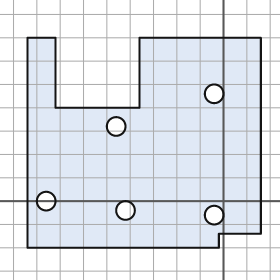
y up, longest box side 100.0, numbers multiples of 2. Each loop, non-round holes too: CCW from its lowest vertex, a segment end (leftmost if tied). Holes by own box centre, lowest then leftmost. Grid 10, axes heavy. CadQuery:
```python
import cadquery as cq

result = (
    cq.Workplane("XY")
    .moveTo(-84.0, -20.0)
    .lineTo(-2.0, -20.0)
    .lineTo(-2.0, -14.0)
    .lineTo(16.0, -14.0)
    .lineTo(16.0, 70.0)
    .lineTo(-36.0, 70.0)
    .lineTo(-36.0, 40.0)
    .lineTo(-72.0, 40.0)
    .lineTo(-72.0, 70.0)
    .lineTo(-84.0, 70.0)
    .close()
    .moveTo(-4.0, -6.0)
    .circle(4.0)
    .moveTo(-42.0, -4.0)
    .circle(4.0)
    .moveTo(-76.0, 0.0)
    .circle(4.0)
    .moveTo(-46.0, 32.0)
    .circle(4.0)
    .moveTo(-4.0, 46.0)
    .circle(4.0)
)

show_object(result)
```